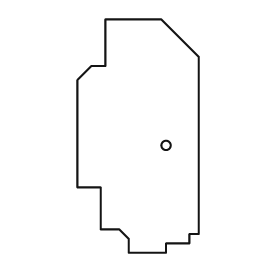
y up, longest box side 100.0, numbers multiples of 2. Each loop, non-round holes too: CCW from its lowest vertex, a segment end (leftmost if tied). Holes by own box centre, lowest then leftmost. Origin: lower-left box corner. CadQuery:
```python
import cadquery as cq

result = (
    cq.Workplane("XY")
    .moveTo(22.0, 0.0)
    .lineTo(38.0, 0.0)
    .lineTo(38.0, 4.0)
    .lineTo(48.0, 4.0)
    .lineTo(48.0, 8.0)
    .lineTo(52.0, 8.0)
    .lineTo(52.0, 84.0)
    .lineTo(36.0, 100.0)
    .lineTo(12.0, 100.0)
    .lineTo(12.0, 80.0)
    .lineTo(6.0, 80.0)
    .lineTo(0.0, 74.0)
    .lineTo(0.0, 28.0)
    .lineTo(10.0, 28.0)
    .lineTo(10.0, 10.0)
    .lineTo(18.0, 10.0)
    .lineTo(22.0, 6.0)
    .close()
    .moveTo(38.0, 46.0)
    .circle(2.0)
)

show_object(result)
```